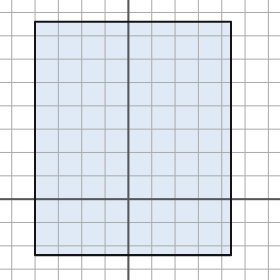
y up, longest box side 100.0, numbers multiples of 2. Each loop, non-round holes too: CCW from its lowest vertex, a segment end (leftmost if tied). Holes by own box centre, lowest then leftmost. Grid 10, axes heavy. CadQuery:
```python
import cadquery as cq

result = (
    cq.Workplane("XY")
    .moveTo(-40.0, -24.0)
    .lineTo(44.0, -24.0)
    .lineTo(44.0, 76.0)
    .lineTo(-40.0, 76.0)
    .close()
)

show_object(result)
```